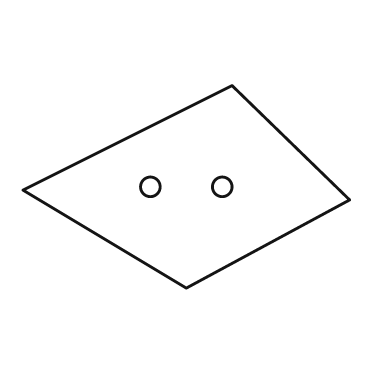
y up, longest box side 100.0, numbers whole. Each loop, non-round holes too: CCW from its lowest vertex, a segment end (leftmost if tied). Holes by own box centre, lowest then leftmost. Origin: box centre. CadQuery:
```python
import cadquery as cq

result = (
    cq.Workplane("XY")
    .moveTo(0.0, -31.0)
    .lineTo(50.0, -4.0)
    .lineTo(14.0, 31.0)
    .lineTo(-50.0, -1.0)
    .close()
    .moveTo(-11.0, 0.0)
    .circle(3.0)
    .moveTo(11.0, 0.0)
    .circle(3.0)
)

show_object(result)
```